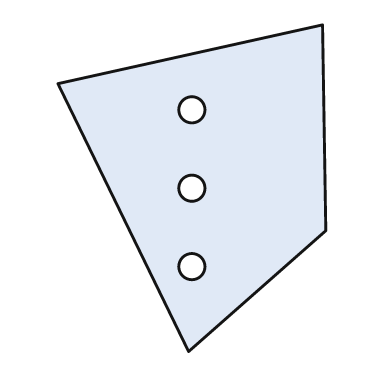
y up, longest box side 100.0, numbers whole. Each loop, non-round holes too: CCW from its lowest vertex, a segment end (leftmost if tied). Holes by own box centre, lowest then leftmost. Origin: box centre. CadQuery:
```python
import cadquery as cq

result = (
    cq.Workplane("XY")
    .moveTo(-1.0, -50.0)
    .lineTo(41.0, -13.0)
    .lineTo(40.0, 50.0)
    .lineTo(-41.0, 32.0)
    .close()
    .moveTo(0.0, -24.0)
    .circle(4.0)
    .moveTo(0.0, 0.0)
    .circle(4.0)
    .moveTo(0.0, 24.0)
    .circle(4.0)
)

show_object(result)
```